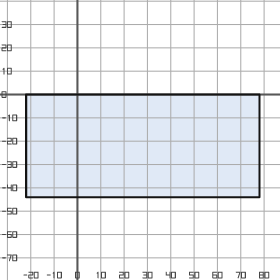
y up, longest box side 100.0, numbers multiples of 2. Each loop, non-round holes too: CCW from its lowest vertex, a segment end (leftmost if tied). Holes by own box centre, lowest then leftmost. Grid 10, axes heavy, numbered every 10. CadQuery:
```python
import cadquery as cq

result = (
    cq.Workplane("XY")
    .moveTo(-22.0, -44.0)
    .lineTo(78.0, -44.0)
    .lineTo(78.0, 0.0)
    .lineTo(-22.0, 0.0)
    .close()
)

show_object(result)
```